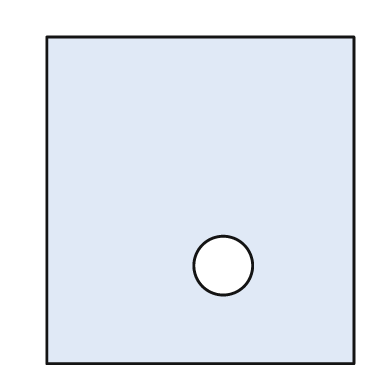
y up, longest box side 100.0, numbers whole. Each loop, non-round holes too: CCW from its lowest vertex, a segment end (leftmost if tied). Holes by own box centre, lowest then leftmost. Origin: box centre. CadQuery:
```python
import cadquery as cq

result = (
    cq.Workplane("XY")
    .moveTo(-47.0, -50.0)
    .lineTo(47.0, -50.0)
    .lineTo(47.0, 50.0)
    .lineTo(-47.0, 50.0)
    .close()
    .moveTo(7.0, -20.0)
    .circle(9.0)
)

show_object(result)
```